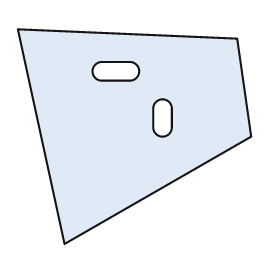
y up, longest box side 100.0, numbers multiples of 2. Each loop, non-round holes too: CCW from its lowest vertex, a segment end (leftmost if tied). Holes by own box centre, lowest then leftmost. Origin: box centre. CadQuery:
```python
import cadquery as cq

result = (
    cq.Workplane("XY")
    .moveTo(-30.0, -46.0)
    .lineTo(50.0, 0.0)
    .lineTo(44.0, 42.0)
    .lineTo(-50.0, 46.0)
    .close()
    .moveTo(8.0, 4.0)
    .threePointArc((12.0, 0.0), (16.0, 4.0))
    .lineTo(16.0, 12.0)
    .threePointArc((12.0, 16.0), (8.0, 12.0))
    .close()
    .moveTo(-14.0, 24.0)
    .lineTo(-2.0, 24.0)
    .threePointArc((2.0, 28.0), (-2.0, 32.0))
    .lineTo(-14.0, 32.0)
    .threePointArc((-18.0, 28.0), (-14.0, 24.0))
    .close()
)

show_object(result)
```